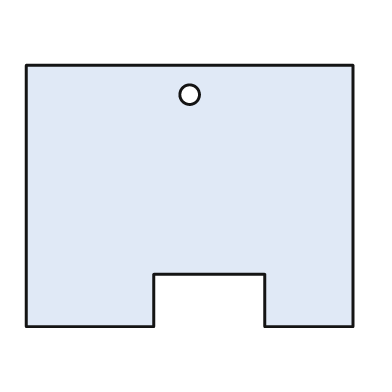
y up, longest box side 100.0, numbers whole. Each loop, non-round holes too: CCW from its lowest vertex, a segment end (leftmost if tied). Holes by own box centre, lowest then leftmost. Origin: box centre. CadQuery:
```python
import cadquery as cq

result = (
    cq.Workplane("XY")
    .moveTo(-50.0, -40.0)
    .lineTo(-11.0, -40.0)
    .lineTo(-11.0, -24.0)
    .lineTo(23.0, -24.0)
    .lineTo(23.0, -40.0)
    .lineTo(50.0, -40.0)
    .lineTo(50.0, 40.0)
    .lineTo(-50.0, 40.0)
    .close()
    .moveTo(0.0, 31.0)
    .circle(3.0)
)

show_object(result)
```